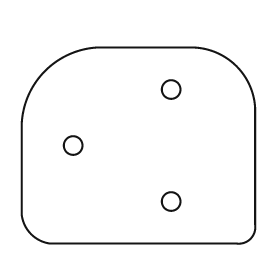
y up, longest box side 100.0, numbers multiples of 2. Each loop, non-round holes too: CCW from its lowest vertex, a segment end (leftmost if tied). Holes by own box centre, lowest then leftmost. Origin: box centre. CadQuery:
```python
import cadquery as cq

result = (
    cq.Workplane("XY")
    .moveTo(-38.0, -42.0)
    .lineTo(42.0, -42.0)
    .threePointArc((48.0, -40.0), (50.0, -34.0))
    .lineTo(50.0, 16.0)
    .threePointArc((42.0, 34.0), (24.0, 42.0))
    .lineTo(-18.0, 42.0)
    .threePointArc((-40.0, 32.0), (-50.0, 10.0))
    .lineTo(-50.0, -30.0)
    .threePointArc((-46.0, -38.0), (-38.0, -42.0))
    .close()
    .moveTo(14.0, -24.0)
    .circle(4.0)
    .moveTo(-28.0, 0.0)
    .circle(4.0)
    .moveTo(14.0, 24.0)
    .circle(4.0)
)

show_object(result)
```